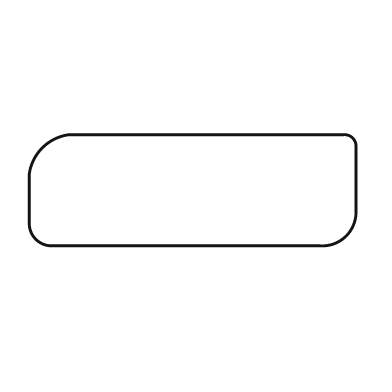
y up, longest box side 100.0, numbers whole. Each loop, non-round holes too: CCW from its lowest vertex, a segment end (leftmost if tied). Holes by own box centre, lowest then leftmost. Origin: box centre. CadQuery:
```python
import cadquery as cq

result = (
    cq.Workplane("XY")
    .moveTo(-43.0, -17.0)
    .lineTo(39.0, -17.0)
    .threePointArc((47.0, -14.0), (50.0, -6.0))
    .lineTo(50.0, 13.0)
    .threePointArc((49.0, 16.0), (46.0, 17.0))
    .lineTo(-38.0, 17.0)
    .threePointArc((-46.0, 13.0), (-50.0, 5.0))
    .lineTo(-50.0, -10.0)
    .threePointArc((-48.0, -15.0), (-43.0, -17.0))
    .close()
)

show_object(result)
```